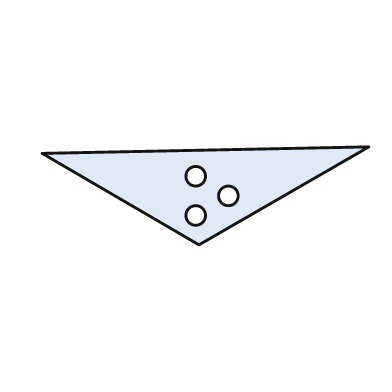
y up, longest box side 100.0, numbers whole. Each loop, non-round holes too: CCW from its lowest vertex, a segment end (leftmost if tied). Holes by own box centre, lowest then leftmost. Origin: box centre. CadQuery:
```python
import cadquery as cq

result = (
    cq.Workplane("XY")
    .moveTo(-2.0, -15.0)
    .lineTo(50.0, 15.0)
    .lineTo(-50.0, 13.0)
    .close()
    .moveTo(-3.0, -6.0)
    .circle(3.0)
    .moveTo(7.0, 0.0)
    .circle(3.0)
    .moveTo(-3.0, 6.0)
    .circle(3.0)
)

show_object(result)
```